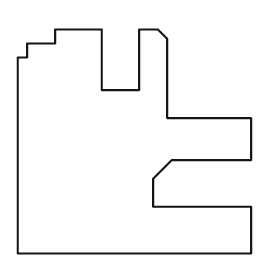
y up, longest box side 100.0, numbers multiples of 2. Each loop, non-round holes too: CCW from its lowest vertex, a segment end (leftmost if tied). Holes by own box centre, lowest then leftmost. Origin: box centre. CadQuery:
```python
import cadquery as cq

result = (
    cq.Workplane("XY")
    .moveTo(-50.0, -48.0)
    .lineTo(50.0, -48.0)
    .lineTo(50.0, -28.0)
    .lineTo(8.0, -28.0)
    .lineTo(8.0, -16.0)
    .lineTo(16.0, -8.0)
    .lineTo(50.0, -8.0)
    .lineTo(50.0, 10.0)
    .lineTo(14.0, 10.0)
    .lineTo(14.0, 44.0)
    .lineTo(10.0, 48.0)
    .lineTo(2.0, 48.0)
    .lineTo(2.0, 22.0)
    .lineTo(-14.0, 22.0)
    .lineTo(-14.0, 48.0)
    .lineTo(-34.0, 48.0)
    .lineTo(-34.0, 42.0)
    .lineTo(-46.0, 42.0)
    .lineTo(-46.0, 36.0)
    .lineTo(-50.0, 36.0)
    .close()
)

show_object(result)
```